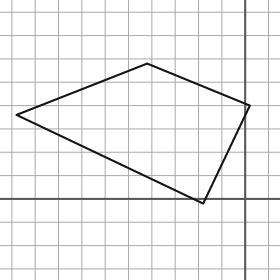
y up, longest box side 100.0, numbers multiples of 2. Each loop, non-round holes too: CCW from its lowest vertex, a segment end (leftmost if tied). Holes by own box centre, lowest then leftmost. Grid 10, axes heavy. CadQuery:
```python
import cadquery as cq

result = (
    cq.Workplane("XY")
    .moveTo(-18.0, -2.0)
    .lineTo(2.0, 40.0)
    .lineTo(-42.0, 58.0)
    .lineTo(-98.0, 36.0)
    .close()
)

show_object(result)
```